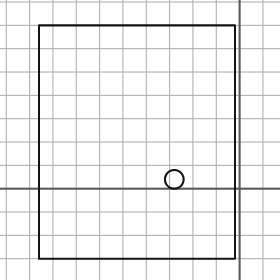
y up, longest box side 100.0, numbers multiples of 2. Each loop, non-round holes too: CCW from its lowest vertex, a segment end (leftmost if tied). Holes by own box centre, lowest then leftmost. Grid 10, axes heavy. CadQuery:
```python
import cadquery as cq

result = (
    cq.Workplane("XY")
    .moveTo(-86.0, -30.0)
    .lineTo(-2.0, -30.0)
    .lineTo(-2.0, 70.0)
    .lineTo(-86.0, 70.0)
    .close()
    .moveTo(-28.0, 4.0)
    .circle(4.0)
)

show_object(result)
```